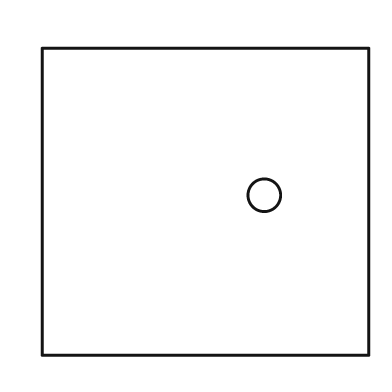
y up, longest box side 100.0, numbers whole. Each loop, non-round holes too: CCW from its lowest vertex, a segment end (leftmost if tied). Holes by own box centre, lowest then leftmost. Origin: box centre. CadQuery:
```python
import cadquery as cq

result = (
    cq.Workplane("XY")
    .moveTo(-50.0, -47.0)
    .lineTo(50.0, -47.0)
    .lineTo(50.0, 47.0)
    .lineTo(-50.0, 47.0)
    .close()
    .moveTo(18.0, 2.0)
    .circle(5.0)
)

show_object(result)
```